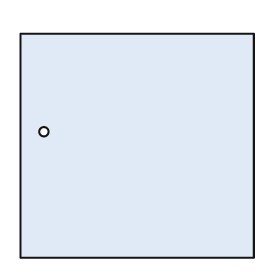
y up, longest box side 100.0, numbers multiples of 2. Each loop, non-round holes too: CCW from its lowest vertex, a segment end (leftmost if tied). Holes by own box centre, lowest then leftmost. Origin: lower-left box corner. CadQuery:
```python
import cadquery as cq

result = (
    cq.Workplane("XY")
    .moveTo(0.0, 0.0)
    .lineTo(100.0, 0.0)
    .lineTo(100.0, 96.0)
    .lineTo(0.0, 96.0)
    .close()
    .moveTo(10.0, 54.0)
    .circle(2.0)
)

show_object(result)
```